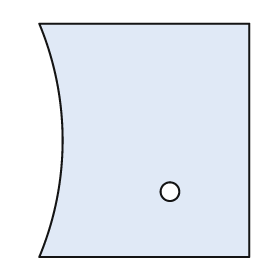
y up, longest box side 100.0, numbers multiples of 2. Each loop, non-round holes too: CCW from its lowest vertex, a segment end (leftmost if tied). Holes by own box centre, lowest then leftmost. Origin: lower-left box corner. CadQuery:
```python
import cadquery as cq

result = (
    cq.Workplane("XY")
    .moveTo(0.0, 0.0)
    .lineTo(90.0, 0.0)
    .lineTo(90.0, 100.0)
    .lineTo(0.0, 100.0)
    .threePointArc((10.0, 50.0), (0.0, 0.0))
    .close()
    .moveTo(56.0, 28.0)
    .circle(4.0)
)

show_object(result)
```